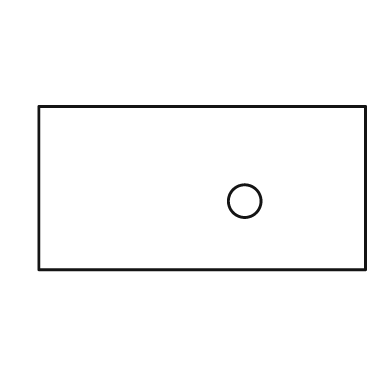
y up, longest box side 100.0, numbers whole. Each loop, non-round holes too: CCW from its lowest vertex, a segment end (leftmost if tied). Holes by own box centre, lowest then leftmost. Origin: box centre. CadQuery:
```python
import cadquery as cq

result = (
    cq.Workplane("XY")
    .moveTo(-50.0, -25.0)
    .lineTo(50.0, -25.0)
    .lineTo(50.0, 25.0)
    .lineTo(-50.0, 25.0)
    .close()
    .moveTo(13.0, -4.0)
    .circle(5.0)
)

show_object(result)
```